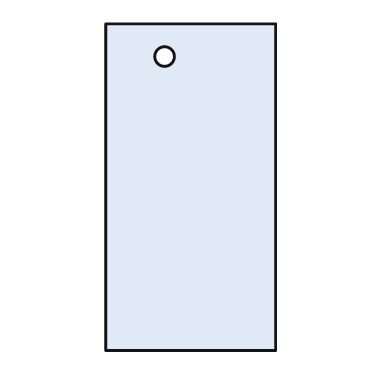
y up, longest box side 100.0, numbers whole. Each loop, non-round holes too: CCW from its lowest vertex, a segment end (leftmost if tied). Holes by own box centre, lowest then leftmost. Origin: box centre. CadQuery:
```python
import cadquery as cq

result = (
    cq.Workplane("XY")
    .moveTo(-26.0, -50.0)
    .lineTo(26.0, -50.0)
    .lineTo(26.0, 50.0)
    .lineTo(-26.0, 50.0)
    .close()
    .moveTo(-8.0, 40.0)
    .circle(3.0)
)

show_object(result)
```